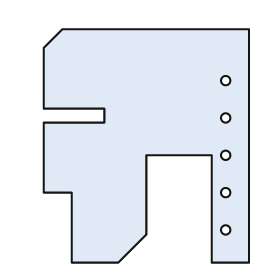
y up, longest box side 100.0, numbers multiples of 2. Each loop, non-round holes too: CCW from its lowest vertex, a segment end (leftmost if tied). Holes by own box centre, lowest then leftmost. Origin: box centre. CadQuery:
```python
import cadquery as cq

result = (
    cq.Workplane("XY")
    .moveTo(-32.0, -50.0)
    .lineTo(-12.0, -50.0)
    .lineTo(0.0, -38.0)
    .lineTo(0.0, -4.0)
    .lineTo(28.0, -4.0)
    .lineTo(28.0, -50.0)
    .lineTo(44.0, -50.0)
    .lineTo(44.0, 50.0)
    .lineTo(-36.0, 50.0)
    .lineTo(-44.0, 42.0)
    .lineTo(-44.0, 16.0)
    .lineTo(-18.0, 16.0)
    .lineTo(-18.0, 10.0)
    .lineTo(-44.0, 10.0)
    .lineTo(-44.0, -20.0)
    .lineTo(-32.0, -20.0)
    .close()
    .moveTo(34.0, -36.0)
    .circle(2.0)
    .moveTo(34.0, -20.0)
    .circle(2.0)
    .moveTo(34.0, -4.0)
    .circle(2.0)
    .moveTo(34.0, 12.0)
    .circle(2.0)
    .moveTo(34.0, 28.0)
    .circle(2.0)
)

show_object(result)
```